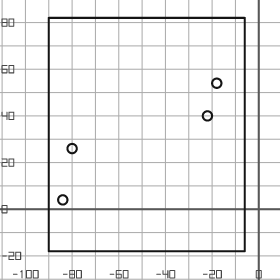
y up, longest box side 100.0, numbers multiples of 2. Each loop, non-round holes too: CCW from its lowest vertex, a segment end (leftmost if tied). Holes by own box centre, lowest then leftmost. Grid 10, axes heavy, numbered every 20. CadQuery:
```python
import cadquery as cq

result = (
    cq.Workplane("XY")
    .moveTo(-90.0, -18.0)
    .lineTo(-6.0, -18.0)
    .lineTo(-6.0, 82.0)
    .lineTo(-90.0, 82.0)
    .close()
    .moveTo(-84.0, 4.0)
    .circle(2.0)
    .moveTo(-80.0, 26.0)
    .circle(2.0)
    .moveTo(-22.0, 40.0)
    .circle(2.0)
    .moveTo(-18.0, 54.0)
    .circle(2.0)
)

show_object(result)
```